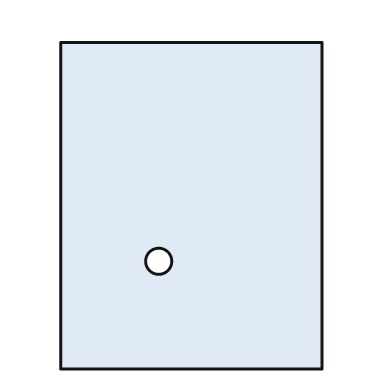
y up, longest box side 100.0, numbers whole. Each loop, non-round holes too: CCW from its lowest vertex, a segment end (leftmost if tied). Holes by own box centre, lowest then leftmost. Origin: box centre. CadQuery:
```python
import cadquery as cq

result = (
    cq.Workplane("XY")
    .moveTo(-40.0, -50.0)
    .lineTo(40.0, -50.0)
    .lineTo(40.0, 50.0)
    .lineTo(-40.0, 50.0)
    .close()
    .moveTo(-10.0, -17.0)
    .circle(4.0)
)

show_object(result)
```